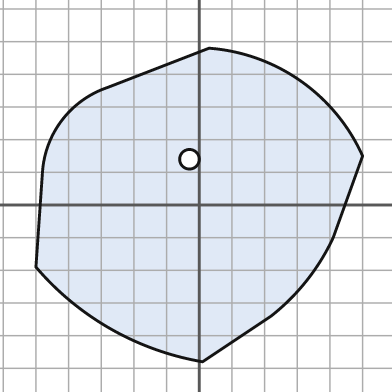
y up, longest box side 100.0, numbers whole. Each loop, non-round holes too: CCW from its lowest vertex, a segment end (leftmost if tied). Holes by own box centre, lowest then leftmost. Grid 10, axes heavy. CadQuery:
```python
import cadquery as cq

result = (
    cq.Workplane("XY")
    .moveTo(1.0, -48.0)
    .lineTo(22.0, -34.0)
    .threePointArc((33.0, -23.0), (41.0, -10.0))
    .lineTo(50.0, 15.0)
    .threePointArc((31.0, 38.0), (3.0, 48.0))
    .lineTo(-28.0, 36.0)
    .threePointArc((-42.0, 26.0), (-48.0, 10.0))
    .lineTo(-50.0, -19.0)
    .threePointArc((-27.0, -38.0), (1.0, -48.0))
    .close()
    .moveTo(-3.0, 14.0)
    .circle(3.0)
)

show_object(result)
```